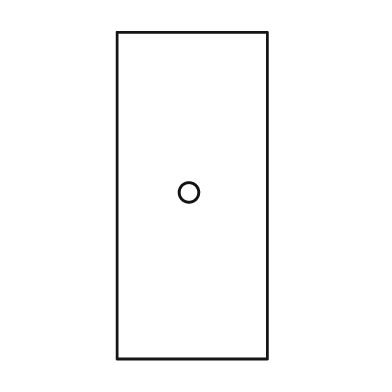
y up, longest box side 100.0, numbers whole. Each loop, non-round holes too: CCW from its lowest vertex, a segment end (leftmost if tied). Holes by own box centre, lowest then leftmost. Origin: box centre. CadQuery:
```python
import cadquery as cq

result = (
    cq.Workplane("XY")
    .moveTo(-23.0, -50.0)
    .lineTo(23.0, -50.0)
    .lineTo(23.0, 50.0)
    .lineTo(-23.0, 50.0)
    .close()
    .moveTo(-1.0, 1.0)
    .circle(3.0)
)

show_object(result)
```